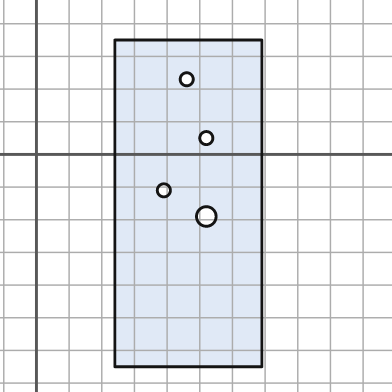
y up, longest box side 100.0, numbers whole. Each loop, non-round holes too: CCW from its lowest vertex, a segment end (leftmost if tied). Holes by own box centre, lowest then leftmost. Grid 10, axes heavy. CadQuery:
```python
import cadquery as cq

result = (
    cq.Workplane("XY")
    .moveTo(24.0, -65.0)
    .lineTo(69.0, -65.0)
    .lineTo(69.0, 35.0)
    .lineTo(24.0, 35.0)
    .close()
    .moveTo(52.0, -19.0)
    .circle(3.0)
    .moveTo(39.0, -11.0)
    .circle(2.0)
    .moveTo(52.0, 5.0)
    .circle(2.0)
    .moveTo(46.0, 23.0)
    .circle(2.0)
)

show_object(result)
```